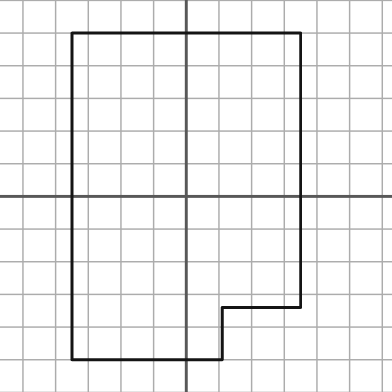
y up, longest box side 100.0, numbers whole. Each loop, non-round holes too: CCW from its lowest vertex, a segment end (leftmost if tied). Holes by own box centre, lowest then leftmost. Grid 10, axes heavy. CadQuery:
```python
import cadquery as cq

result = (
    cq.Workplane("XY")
    .moveTo(-35.0, -50.0)
    .lineTo(11.0, -50.0)
    .lineTo(11.0, -34.0)
    .lineTo(35.0, -34.0)
    .lineTo(35.0, 50.0)
    .lineTo(-35.0, 50.0)
    .close()
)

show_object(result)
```